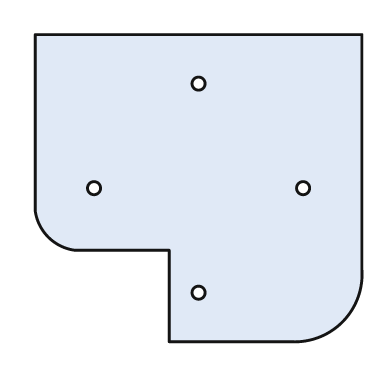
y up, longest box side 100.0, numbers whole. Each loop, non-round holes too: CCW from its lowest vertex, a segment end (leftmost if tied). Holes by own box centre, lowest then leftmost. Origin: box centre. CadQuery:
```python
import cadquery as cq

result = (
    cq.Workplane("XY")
    .moveTo(-9.0, -47.0)
    .lineTo(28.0, -47.0)
    .threePointArc((44.0, -41.0), (50.0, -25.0))
    .lineTo(50.0, 47.0)
    .lineTo(-50.0, 47.0)
    .lineTo(-50.0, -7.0)
    .threePointArc((-46.0, -15.0), (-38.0, -19.0))
    .lineTo(-9.0, -19.0)
    .close()
    .moveTo(0.0, -32.0)
    .circle(2.0)
    .moveTo(-32.0, 0.0)
    .circle(2.0)
    .moveTo(32.0, 0.0)
    .circle(2.0)
    .moveTo(0.0, 32.0)
    .circle(2.0)
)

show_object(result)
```